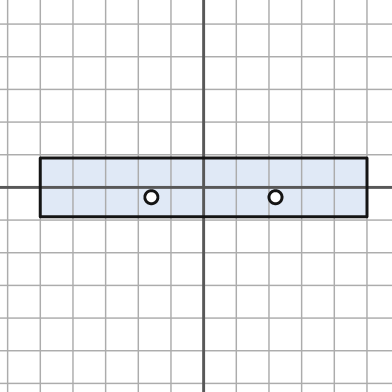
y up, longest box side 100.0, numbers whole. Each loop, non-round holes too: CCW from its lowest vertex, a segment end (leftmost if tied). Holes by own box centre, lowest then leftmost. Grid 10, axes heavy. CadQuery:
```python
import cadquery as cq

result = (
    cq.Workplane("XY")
    .moveTo(-50.0, -9.0)
    .lineTo(50.0, -9.0)
    .lineTo(50.0, 9.0)
    .lineTo(-50.0, 9.0)
    .close()
    .moveTo(-16.0, -3.0)
    .circle(2.0)
    .moveTo(22.0, -3.0)
    .circle(2.0)
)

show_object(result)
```